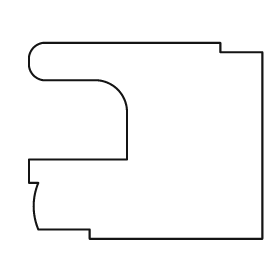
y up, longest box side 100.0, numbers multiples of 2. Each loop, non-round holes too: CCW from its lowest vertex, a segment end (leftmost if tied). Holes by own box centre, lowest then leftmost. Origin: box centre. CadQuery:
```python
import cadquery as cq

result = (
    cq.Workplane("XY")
    .moveTo(-24.0, -42.0)
    .lineTo(50.0, -42.0)
    .lineTo(50.0, 38.0)
    .lineTo(32.0, 38.0)
    .lineTo(32.0, 42.0)
    .lineTo(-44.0, 42.0)
    .threePointArc((-48.0, 40.0), (-50.0, 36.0))
    .lineTo(-50.0, 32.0)
    .threePointArc((-48.0, 28.0), (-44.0, 26.0))
    .lineTo(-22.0, 26.0)
    .threePointArc((-12.0, 22.0), (-8.0, 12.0))
    .lineTo(-8.0, -8.0)
    .lineTo(-50.0, -8.0)
    .lineTo(-50.0, -18.0)
    .lineTo(-46.0, -18.0)
    .threePointArc((-48.0, -28.0), (-46.0, -38.0))
    .lineTo(-24.0, -38.0)
    .close()
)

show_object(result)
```